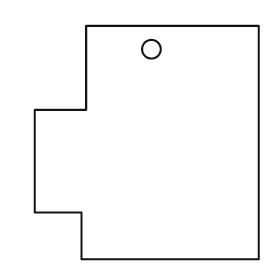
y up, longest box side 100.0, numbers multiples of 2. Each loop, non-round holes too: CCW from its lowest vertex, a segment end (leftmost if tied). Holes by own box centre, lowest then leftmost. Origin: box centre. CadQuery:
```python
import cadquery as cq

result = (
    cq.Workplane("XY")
    .moveTo(-28.0, -50.0)
    .lineTo(48.0, -50.0)
    .lineTo(48.0, 50.0)
    .lineTo(-26.0, 50.0)
    .lineTo(-26.0, 14.0)
    .lineTo(-48.0, 14.0)
    .lineTo(-48.0, -30.0)
    .lineTo(-28.0, -30.0)
    .close()
    .moveTo(2.0, 40.0)
    .circle(4.0)
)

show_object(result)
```